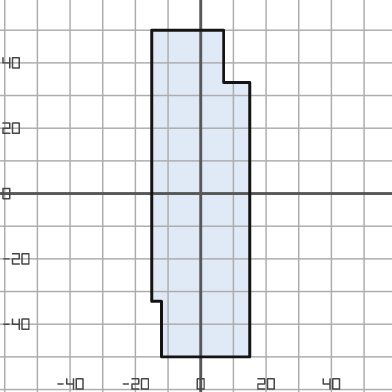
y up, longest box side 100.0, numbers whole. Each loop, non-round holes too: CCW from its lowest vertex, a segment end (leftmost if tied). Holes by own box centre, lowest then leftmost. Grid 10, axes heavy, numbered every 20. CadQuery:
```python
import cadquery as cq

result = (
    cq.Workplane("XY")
    .moveTo(-12.0, -50.0)
    .lineTo(15.0, -50.0)
    .lineTo(15.0, 34.0)
    .lineTo(7.0, 34.0)
    .lineTo(7.0, 50.0)
    .lineTo(-15.0, 50.0)
    .lineTo(-15.0, -33.0)
    .lineTo(-12.0, -33.0)
    .close()
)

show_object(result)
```